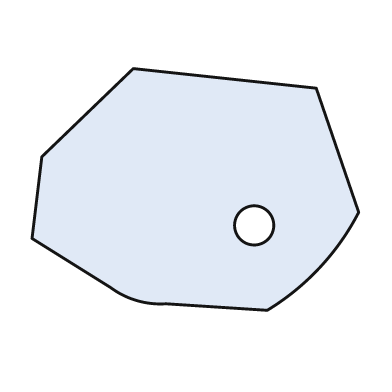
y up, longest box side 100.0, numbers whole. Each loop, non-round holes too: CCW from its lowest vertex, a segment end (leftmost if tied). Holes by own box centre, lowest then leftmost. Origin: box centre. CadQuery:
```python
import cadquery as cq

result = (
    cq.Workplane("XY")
    .moveTo(22.0, -37.0)
    .threePointArc((38.0, -24.0), (50.0, -7.0))
    .lineTo(37.0, 31.0)
    .lineTo(-19.0, 37.0)
    .lineTo(-47.0, 10.0)
    .lineTo(-50.0, -15.0)
    .lineTo(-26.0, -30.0)
    .threePointArc((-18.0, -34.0), (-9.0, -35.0))
    .close()
    .moveTo(18.0, -11.0)
    .circle(6.0)
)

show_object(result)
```